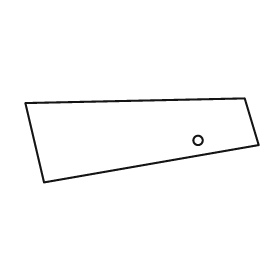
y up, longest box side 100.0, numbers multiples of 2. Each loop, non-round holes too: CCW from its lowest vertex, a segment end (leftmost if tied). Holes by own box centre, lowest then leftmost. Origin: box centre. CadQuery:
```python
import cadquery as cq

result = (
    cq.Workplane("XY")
    .moveTo(-42.0, -18.0)
    .lineTo(50.0, -2.0)
    .lineTo(44.0, 18.0)
    .lineTo(-50.0, 16.0)
    .close()
    .moveTo(24.0, 0.0)
    .circle(2.0)
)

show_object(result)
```